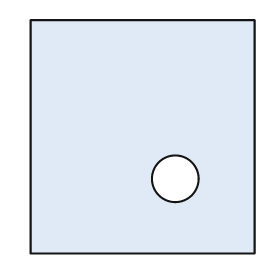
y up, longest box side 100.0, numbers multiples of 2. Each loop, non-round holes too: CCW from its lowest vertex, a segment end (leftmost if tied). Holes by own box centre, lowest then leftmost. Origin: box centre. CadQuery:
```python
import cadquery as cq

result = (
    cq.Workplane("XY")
    .moveTo(-48.0, -50.0)
    .lineTo(48.0, -50.0)
    .lineTo(48.0, 50.0)
    .lineTo(-48.0, 50.0)
    .close()
    .moveTo(14.0, -18.0)
    .circle(10.0)
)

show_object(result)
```